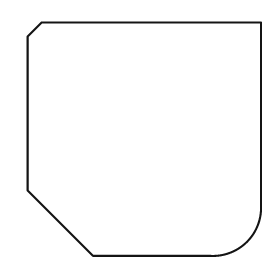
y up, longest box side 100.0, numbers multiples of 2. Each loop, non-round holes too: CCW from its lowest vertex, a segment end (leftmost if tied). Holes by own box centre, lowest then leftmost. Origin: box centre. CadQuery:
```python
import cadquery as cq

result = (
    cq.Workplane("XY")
    .moveTo(-22.0, -50.0)
    .lineTo(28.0, -50.0)
    .threePointArc((44.0, -44.0), (50.0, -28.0))
    .lineTo(50.0, 50.0)
    .lineTo(-44.0, 50.0)
    .lineTo(-50.0, 44.0)
    .lineTo(-50.0, -22.0)
    .close()
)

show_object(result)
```